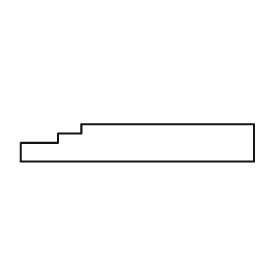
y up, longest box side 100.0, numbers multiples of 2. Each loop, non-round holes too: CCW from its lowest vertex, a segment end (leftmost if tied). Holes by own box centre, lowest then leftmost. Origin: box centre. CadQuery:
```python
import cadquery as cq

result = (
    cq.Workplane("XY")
    .moveTo(-50.0, -8.0)
    .lineTo(50.0, -8.0)
    .lineTo(50.0, 8.0)
    .lineTo(-24.0, 8.0)
    .lineTo(-24.0, 4.0)
    .lineTo(-34.0, 4.0)
    .lineTo(-34.0, 0.0)
    .lineTo(-50.0, 0.0)
    .close()
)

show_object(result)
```